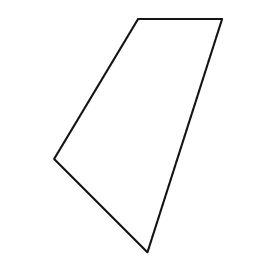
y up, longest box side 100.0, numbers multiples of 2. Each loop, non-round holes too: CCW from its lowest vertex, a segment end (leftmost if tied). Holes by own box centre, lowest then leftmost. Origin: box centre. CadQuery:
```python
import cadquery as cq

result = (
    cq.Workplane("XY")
    .moveTo(4.0, -50.0)
    .lineTo(36.0, 50.0)
    .lineTo(0.0, 50.0)
    .lineTo(-36.0, -10.0)
    .close()
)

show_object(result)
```